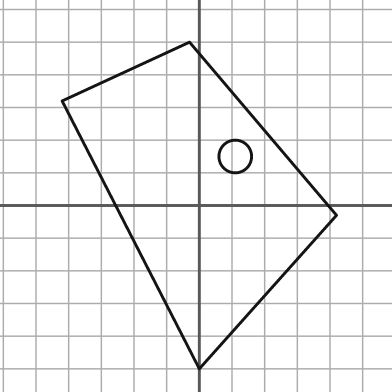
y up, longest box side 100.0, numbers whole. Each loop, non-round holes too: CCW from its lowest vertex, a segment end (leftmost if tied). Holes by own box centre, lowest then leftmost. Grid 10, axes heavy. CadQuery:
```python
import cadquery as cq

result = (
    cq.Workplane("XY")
    .moveTo(0.0, -50.0)
    .lineTo(42.0, -3.0)
    .lineTo(-3.0, 50.0)
    .lineTo(-42.0, 32.0)
    .close()
    .moveTo(11.0, 15.0)
    .circle(5.0)
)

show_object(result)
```